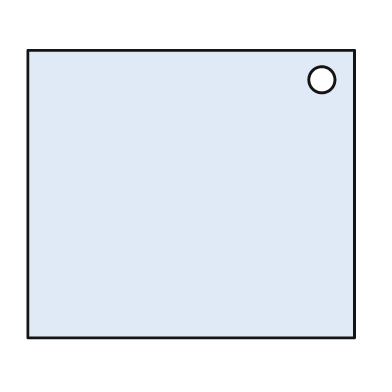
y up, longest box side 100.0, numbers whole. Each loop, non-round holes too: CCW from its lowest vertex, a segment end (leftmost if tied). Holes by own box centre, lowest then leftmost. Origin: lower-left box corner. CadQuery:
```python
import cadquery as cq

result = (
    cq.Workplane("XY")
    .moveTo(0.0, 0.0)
    .lineTo(100.0, 0.0)
    .lineTo(100.0, 88.0)
    .lineTo(0.0, 88.0)
    .close()
    .moveTo(90.0, 79.0)
    .circle(4.0)
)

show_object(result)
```